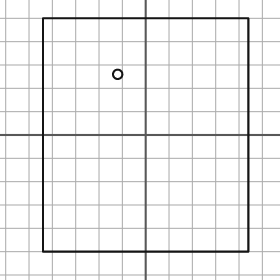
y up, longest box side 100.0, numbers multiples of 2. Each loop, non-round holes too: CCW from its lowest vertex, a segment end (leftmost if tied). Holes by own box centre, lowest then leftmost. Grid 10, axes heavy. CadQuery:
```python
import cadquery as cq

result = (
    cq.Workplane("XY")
    .moveTo(-44.0, -50.0)
    .lineTo(44.0, -50.0)
    .lineTo(44.0, 50.0)
    .lineTo(-44.0, 50.0)
    .close()
    .moveTo(-12.0, 26.0)
    .circle(2.0)
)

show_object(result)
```